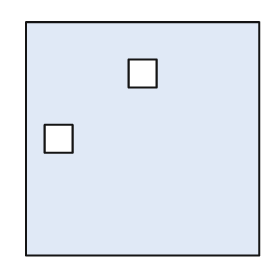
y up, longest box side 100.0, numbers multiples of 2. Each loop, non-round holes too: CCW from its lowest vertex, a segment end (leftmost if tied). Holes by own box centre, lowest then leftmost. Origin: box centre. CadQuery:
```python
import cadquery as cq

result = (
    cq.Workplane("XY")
    .moveTo(-50.0, -50.0)
    .lineTo(50.0, -50.0)
    .lineTo(50.0, 50.0)
    .lineTo(-50.0, 50.0)
    .close()
    .moveTo(-42.0, -6.0)
    .lineTo(-30.0, -6.0)
    .lineTo(-30.0, 6.0)
    .lineTo(-42.0, 6.0)
    .close()
    .moveTo(-6.0, 22.0)
    .lineTo(6.0, 22.0)
    .lineTo(6.0, 34.0)
    .lineTo(-6.0, 34.0)
    .close()
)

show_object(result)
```